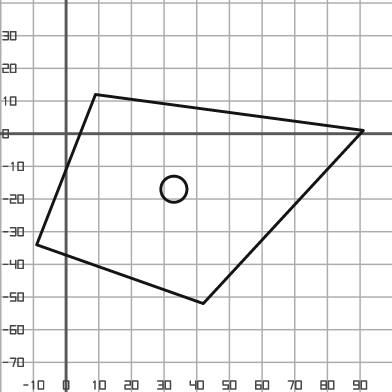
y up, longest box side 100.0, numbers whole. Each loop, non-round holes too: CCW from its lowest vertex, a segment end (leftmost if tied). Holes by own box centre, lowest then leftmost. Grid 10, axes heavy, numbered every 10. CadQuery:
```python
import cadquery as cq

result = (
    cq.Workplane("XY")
    .moveTo(42.0, -52.0)
    .lineTo(91.0, 1.0)
    .lineTo(9.0, 12.0)
    .lineTo(-9.0, -34.0)
    .close()
    .moveTo(33.0, -17.0)
    .circle(4.0)
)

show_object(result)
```